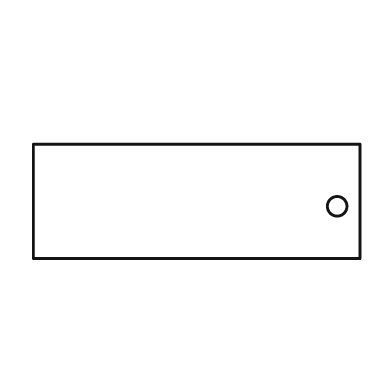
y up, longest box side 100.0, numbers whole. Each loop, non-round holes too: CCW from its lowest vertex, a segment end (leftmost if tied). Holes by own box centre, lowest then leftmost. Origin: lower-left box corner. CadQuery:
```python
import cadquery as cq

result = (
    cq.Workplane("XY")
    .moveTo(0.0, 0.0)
    .lineTo(100.0, 0.0)
    .lineTo(100.0, 35.0)
    .lineTo(0.0, 35.0)
    .close()
    .moveTo(93.0, 16.0)
    .circle(3.0)
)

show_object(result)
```